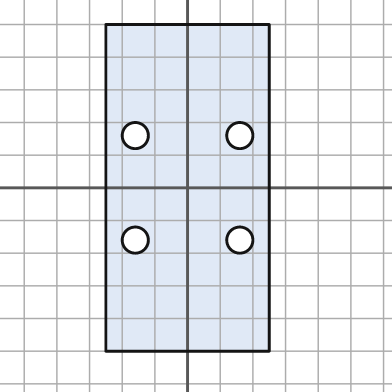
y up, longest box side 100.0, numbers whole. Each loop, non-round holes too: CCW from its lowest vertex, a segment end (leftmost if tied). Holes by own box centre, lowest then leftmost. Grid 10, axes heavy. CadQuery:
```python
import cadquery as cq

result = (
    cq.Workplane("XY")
    .moveTo(-25.0, -50.0)
    .lineTo(25.0, -50.0)
    .lineTo(25.0, 50.0)
    .lineTo(-25.0, 50.0)
    .close()
    .moveTo(-16.0, -16.0)
    .circle(4.0)
    .moveTo(16.0, -16.0)
    .circle(4.0)
    .moveTo(-16.0, 16.0)
    .circle(4.0)
    .moveTo(16.0, 16.0)
    .circle(4.0)
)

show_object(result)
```